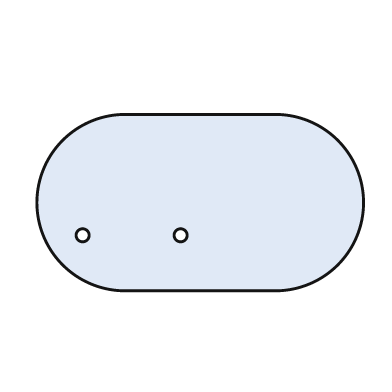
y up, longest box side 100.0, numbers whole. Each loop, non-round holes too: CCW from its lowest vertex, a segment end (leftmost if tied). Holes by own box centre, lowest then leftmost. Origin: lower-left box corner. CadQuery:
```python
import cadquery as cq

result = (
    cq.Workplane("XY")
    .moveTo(27.0, 0.0)
    .lineTo(73.0, 0.0)
    .threePointArc((100.0, 27.0), (73.0, 54.0))
    .lineTo(27.0, 54.0)
    .threePointArc((0.0, 27.0), (27.0, 0.0))
    .close()
    .moveTo(14.0, 17.0)
    .circle(2.0)
    .moveTo(44.0, 17.0)
    .circle(2.0)
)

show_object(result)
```